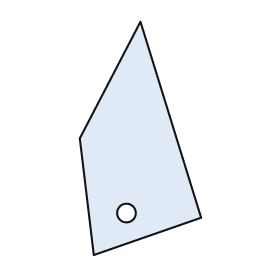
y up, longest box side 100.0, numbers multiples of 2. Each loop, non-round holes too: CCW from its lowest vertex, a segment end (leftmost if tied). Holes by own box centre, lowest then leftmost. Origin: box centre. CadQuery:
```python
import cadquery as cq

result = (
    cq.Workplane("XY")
    .moveTo(-20.0, -50.0)
    .lineTo(26.0, -34.0)
    .lineTo(0.0, 50.0)
    .lineTo(-26.0, 0.0)
    .close()
    .moveTo(-6.0, -32.0)
    .circle(4.0)
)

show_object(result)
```